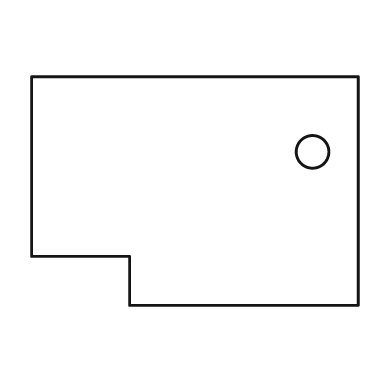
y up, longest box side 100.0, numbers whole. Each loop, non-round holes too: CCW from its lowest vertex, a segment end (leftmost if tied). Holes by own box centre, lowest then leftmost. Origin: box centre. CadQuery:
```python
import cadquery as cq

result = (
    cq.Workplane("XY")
    .moveTo(-20.0, -35.0)
    .lineTo(50.0, -35.0)
    .lineTo(50.0, 35.0)
    .lineTo(-50.0, 35.0)
    .lineTo(-50.0, -20.0)
    .lineTo(-20.0, -20.0)
    .close()
    .moveTo(36.0, 12.0)
    .circle(5.0)
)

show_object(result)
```